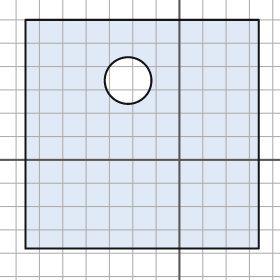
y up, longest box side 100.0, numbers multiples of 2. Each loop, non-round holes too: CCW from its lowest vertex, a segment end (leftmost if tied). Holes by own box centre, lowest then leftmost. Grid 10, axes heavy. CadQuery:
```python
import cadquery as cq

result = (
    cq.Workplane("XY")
    .moveTo(-66.0, -38.0)
    .lineTo(34.0, -38.0)
    .lineTo(34.0, 60.0)
    .lineTo(-66.0, 60.0)
    .close()
    .moveTo(-22.0, 34.0)
    .circle(10.0)
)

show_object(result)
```